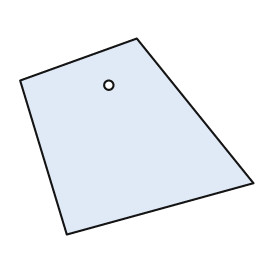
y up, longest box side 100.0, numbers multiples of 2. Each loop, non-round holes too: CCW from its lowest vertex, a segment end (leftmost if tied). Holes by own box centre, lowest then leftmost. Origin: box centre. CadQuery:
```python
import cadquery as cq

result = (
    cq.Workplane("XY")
    .moveTo(-30.0, -42.0)
    .lineTo(50.0, -20.0)
    .lineTo(0.0, 42.0)
    .lineTo(-50.0, 24.0)
    .close()
    .moveTo(-12.0, 22.0)
    .circle(2.0)
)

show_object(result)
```